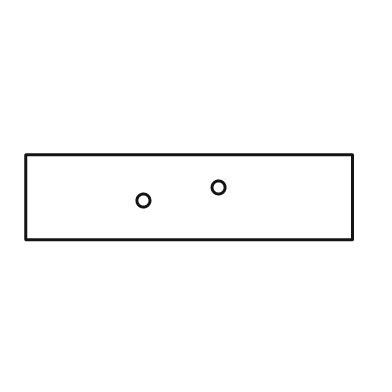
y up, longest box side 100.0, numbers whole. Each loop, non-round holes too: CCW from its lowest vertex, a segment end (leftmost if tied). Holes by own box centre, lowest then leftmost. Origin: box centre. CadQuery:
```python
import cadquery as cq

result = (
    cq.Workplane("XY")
    .moveTo(-50.0, -13.0)
    .lineTo(50.0, -13.0)
    .lineTo(50.0, 13.0)
    .lineTo(-50.0, 13.0)
    .close()
    .moveTo(-14.0, -1.0)
    .circle(2.0)
    .moveTo(9.0, 3.0)
    .circle(2.0)
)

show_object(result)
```